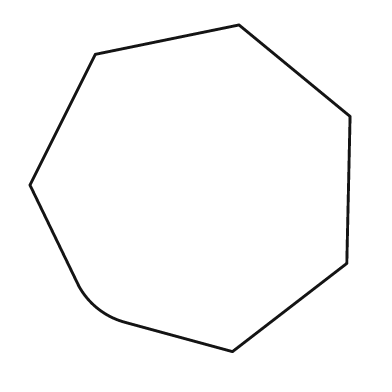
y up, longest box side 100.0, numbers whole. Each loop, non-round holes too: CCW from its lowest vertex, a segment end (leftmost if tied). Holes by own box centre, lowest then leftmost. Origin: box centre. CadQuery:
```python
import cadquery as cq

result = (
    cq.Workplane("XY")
    .moveTo(13.0, -50.0)
    .lineTo(48.0, -23.0)
    .lineTo(49.0, 22.0)
    .lineTo(15.0, 50.0)
    .lineTo(-29.0, 41.0)
    .lineTo(-49.0, 1.0)
    .lineTo(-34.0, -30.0)
    .threePointArc((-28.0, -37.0), (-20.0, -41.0))
    .close()
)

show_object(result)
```